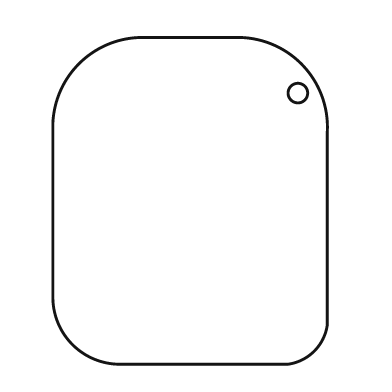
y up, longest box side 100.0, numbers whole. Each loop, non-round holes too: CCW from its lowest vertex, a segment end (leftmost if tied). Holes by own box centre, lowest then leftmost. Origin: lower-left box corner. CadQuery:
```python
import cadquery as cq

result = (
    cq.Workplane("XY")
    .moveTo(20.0, 0.0)
    .lineTo(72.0, 0.0)
    .threePointArc((80.0, 4.0), (84.0, 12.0))
    .lineTo(84.0, 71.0)
    .threePointArc((76.0, 92.0), (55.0, 100.0))
    .lineTo(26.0, 100.0)
    .threePointArc((8.0, 92.0), (0.0, 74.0))
    .lineTo(0.0, 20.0)
    .threePointArc((6.0, 6.0), (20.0, 0.0))
    .close()
    .moveTo(75.0, 83.0)
    .circle(3.0)
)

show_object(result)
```